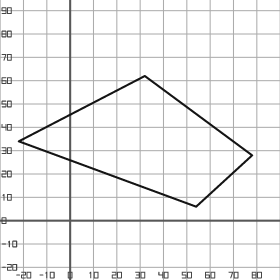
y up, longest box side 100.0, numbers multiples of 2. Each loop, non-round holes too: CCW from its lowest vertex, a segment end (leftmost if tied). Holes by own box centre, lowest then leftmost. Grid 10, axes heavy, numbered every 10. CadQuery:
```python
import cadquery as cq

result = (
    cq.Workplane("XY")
    .moveTo(54.0, 6.0)
    .lineTo(78.0, 28.0)
    .lineTo(32.0, 62.0)
    .lineTo(-22.0, 34.0)
    .close()
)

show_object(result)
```